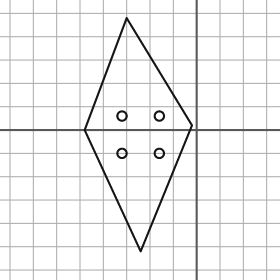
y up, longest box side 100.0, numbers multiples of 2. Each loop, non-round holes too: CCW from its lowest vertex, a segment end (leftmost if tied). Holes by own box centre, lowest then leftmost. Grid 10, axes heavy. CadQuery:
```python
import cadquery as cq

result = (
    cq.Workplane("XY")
    .moveTo(-24.0, -52.0)
    .lineTo(-2.0, 2.0)
    .lineTo(-30.0, 48.0)
    .lineTo(-48.0, 0.0)
    .close()
    .moveTo(-32.0, -10.0)
    .circle(2.0)
    .moveTo(-16.0, -10.0)
    .circle(2.0)
    .moveTo(-32.0, 6.0)
    .circle(2.0)
    .moveTo(-16.0, 6.0)
    .circle(2.0)
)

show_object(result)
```